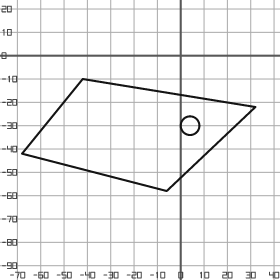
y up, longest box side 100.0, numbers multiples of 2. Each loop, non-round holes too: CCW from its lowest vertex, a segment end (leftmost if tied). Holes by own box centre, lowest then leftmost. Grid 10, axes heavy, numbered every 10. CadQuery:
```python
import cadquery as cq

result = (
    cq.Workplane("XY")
    .moveTo(-6.0, -58.0)
    .lineTo(32.0, -22.0)
    .lineTo(-42.0, -10.0)
    .lineTo(-68.0, -42.0)
    .close()
    .moveTo(4.0, -30.0)
    .circle(4.0)
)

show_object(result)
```